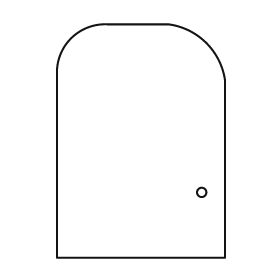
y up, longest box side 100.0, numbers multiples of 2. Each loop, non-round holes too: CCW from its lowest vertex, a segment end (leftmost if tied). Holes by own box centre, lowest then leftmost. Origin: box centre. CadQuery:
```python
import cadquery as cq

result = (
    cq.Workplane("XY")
    .moveTo(-36.0, -50.0)
    .lineTo(36.0, -50.0)
    .lineTo(36.0, 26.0)
    .threePointArc((28.0, 42.0), (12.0, 50.0))
    .lineTo(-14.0, 50.0)
    .threePointArc((-30.0, 44.0), (-36.0, 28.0))
    .close()
    .moveTo(26.0, -22.0)
    .circle(2.0)
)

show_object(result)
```